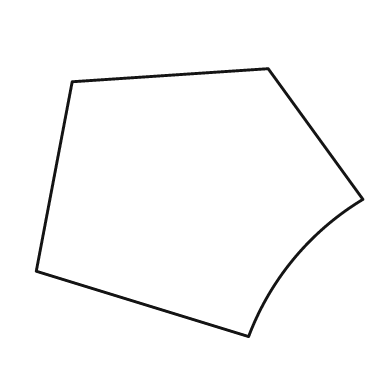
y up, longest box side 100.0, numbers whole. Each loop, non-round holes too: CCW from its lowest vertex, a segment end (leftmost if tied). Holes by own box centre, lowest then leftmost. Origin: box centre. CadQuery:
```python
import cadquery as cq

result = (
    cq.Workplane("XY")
    .moveTo(15.0, -41.0)
    .threePointArc((29.0, -17.0), (50.0, 1.0))
    .lineTo(21.0, 41.0)
    .lineTo(-39.0, 37.0)
    .lineTo(-50.0, -21.0)
    .close()
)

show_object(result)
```